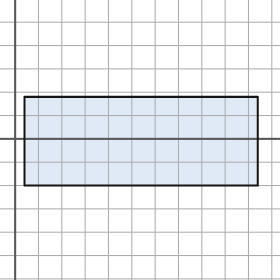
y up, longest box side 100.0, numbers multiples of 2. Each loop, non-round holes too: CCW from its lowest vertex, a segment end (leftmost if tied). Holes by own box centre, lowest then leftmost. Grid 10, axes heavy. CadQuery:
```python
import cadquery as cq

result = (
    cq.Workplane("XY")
    .moveTo(4.0, -20.0)
    .lineTo(104.0, -20.0)
    .lineTo(104.0, 18.0)
    .lineTo(4.0, 18.0)
    .close()
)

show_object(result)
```